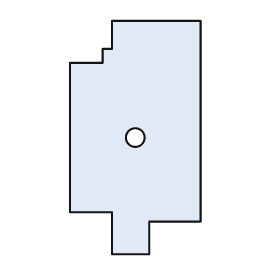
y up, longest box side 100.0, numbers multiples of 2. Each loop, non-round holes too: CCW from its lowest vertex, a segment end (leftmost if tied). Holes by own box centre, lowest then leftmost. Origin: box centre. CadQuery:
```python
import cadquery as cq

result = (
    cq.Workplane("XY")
    .moveTo(-10.0, -50.0)
    .lineTo(6.0, -50.0)
    .lineTo(6.0, -36.0)
    .lineTo(28.0, -36.0)
    .lineTo(28.0, 50.0)
    .lineTo(-10.0, 50.0)
    .lineTo(-10.0, 38.0)
    .lineTo(-14.0, 38.0)
    .lineTo(-14.0, 32.0)
    .lineTo(-28.0, 32.0)
    .lineTo(-28.0, -32.0)
    .lineTo(-10.0, -32.0)
    .close()
    .moveTo(0.0, 0.0)
    .circle(4.0)
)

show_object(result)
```